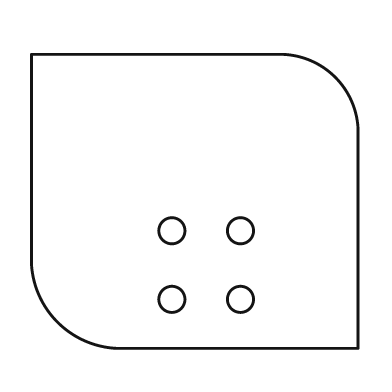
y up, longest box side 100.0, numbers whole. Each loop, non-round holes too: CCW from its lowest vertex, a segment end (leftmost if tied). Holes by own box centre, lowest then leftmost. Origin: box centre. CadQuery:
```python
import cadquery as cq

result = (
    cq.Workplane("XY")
    .moveTo(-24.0, -45.0)
    .lineTo(50.0, -45.0)
    .lineTo(50.0, 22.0)
    .threePointArc((43.0, 38.0), (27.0, 45.0))
    .lineTo(-50.0, 45.0)
    .lineTo(-50.0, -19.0)
    .threePointArc((-42.0, -37.0), (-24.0, -45.0))
    .close()
    .moveTo(-7.0, -30.0)
    .circle(4.0)
    .moveTo(14.0, -30.0)
    .circle(4.0)
    .moveTo(-7.0, -9.0)
    .circle(4.0)
    .moveTo(14.0, -9.0)
    .circle(4.0)
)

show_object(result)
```